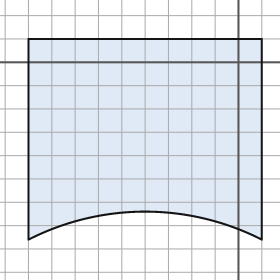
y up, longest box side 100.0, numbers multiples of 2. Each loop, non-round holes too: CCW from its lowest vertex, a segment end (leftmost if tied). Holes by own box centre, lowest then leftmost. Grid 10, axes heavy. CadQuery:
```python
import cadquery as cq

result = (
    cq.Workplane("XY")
    .moveTo(-90.0, -76.0)
    .threePointArc((-40.0, -64.0), (10.0, -76.0))
    .lineTo(10.0, 10.0)
    .lineTo(-90.0, 10.0)
    .close()
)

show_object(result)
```